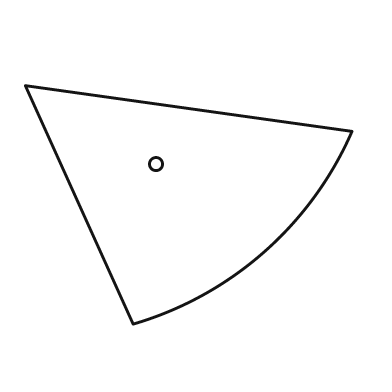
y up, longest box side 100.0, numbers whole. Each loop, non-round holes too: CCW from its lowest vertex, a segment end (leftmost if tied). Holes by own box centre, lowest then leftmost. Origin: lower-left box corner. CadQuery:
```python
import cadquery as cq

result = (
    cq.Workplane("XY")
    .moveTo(33.0, 0.0)
    .threePointArc((73.0, 22.0), (100.0, 59.0))
    .lineTo(0.0, 73.0)
    .close()
    .moveTo(40.0, 49.0)
    .circle(2.0)
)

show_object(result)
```